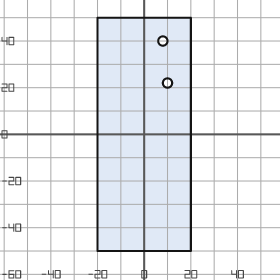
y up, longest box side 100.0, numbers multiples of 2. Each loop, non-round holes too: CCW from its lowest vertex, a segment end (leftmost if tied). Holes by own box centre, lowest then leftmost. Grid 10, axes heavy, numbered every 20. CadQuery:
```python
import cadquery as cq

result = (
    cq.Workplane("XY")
    .moveTo(-20.0, -50.0)
    .lineTo(20.0, -50.0)
    .lineTo(20.0, 50.0)
    .lineTo(-20.0, 50.0)
    .close()
    .moveTo(10.0, 22.0)
    .circle(2.0)
    .moveTo(8.0, 40.0)
    .circle(2.0)
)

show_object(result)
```